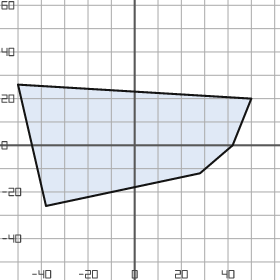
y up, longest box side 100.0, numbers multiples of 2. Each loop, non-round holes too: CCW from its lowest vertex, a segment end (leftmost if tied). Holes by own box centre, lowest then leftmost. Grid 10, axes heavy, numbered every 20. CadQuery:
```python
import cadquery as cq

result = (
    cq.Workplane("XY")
    .moveTo(-38.0, -26.0)
    .lineTo(28.0, -12.0)
    .lineTo(42.0, 0.0)
    .lineTo(50.0, 20.0)
    .lineTo(-50.0, 26.0)
    .close()
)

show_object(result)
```